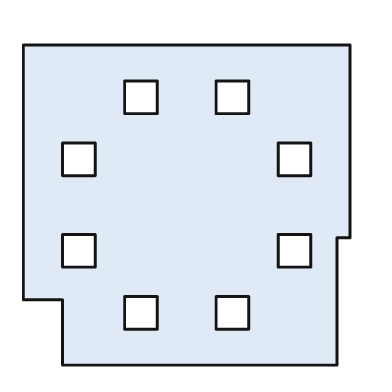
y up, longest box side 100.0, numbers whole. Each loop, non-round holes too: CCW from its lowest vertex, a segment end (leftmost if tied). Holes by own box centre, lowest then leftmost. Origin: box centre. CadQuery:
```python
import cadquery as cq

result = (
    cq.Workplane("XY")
    .moveTo(-38.0, -49.0)
    .lineTo(46.0, -49.0)
    .lineTo(46.0, -10.0)
    .lineTo(50.0, -10.0)
    .lineTo(50.0, 49.0)
    .lineTo(-50.0, 49.0)
    .lineTo(-50.0, -29.0)
    .lineTo(-38.0, -29.0)
    .close()
    .moveTo(-19.0, -38.0)
    .lineTo(-9.0, -38.0)
    .lineTo(-9.0, -28.0)
    .lineTo(-19.0, -28.0)
    .close()
    .moveTo(9.0, -38.0)
    .lineTo(19.0, -38.0)
    .lineTo(19.0, -28.0)
    .lineTo(9.0, -28.0)
    .close()
    .moveTo(-38.0, -19.0)
    .lineTo(-28.0, -19.0)
    .lineTo(-28.0, -9.0)
    .lineTo(-38.0, -9.0)
    .close()
    .moveTo(28.0, -19.0)
    .lineTo(38.0, -19.0)
    .lineTo(38.0, -9.0)
    .lineTo(28.0, -9.0)
    .close()
    .moveTo(-38.0, 9.0)
    .lineTo(-28.0, 9.0)
    .lineTo(-28.0, 19.0)
    .lineTo(-38.0, 19.0)
    .close()
    .moveTo(28.0, 9.0)
    .lineTo(38.0, 9.0)
    .lineTo(38.0, 19.0)
    .lineTo(28.0, 19.0)
    .close()
    .moveTo(-19.0, 28.0)
    .lineTo(-9.0, 28.0)
    .lineTo(-9.0, 38.0)
    .lineTo(-19.0, 38.0)
    .close()
    .moveTo(9.0, 28.0)
    .lineTo(19.0, 28.0)
    .lineTo(19.0, 38.0)
    .lineTo(9.0, 38.0)
    .close()
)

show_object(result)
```